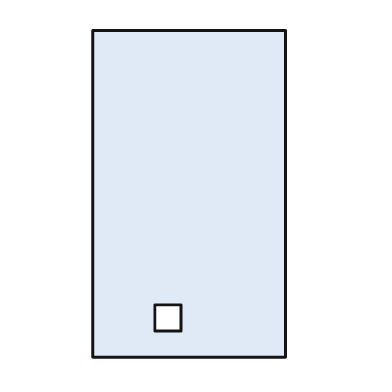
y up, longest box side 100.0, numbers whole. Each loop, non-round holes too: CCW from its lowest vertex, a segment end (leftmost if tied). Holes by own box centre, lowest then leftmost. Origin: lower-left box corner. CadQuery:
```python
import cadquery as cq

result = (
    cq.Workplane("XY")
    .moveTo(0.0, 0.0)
    .lineTo(59.0, 0.0)
    .lineTo(59.0, 100.0)
    .lineTo(0.0, 100.0)
    .close()
    .moveTo(19.0, 8.0)
    .lineTo(27.0, 8.0)
    .lineTo(27.0, 16.0)
    .lineTo(19.0, 16.0)
    .close()
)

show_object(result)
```